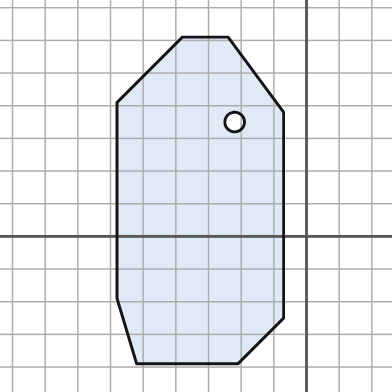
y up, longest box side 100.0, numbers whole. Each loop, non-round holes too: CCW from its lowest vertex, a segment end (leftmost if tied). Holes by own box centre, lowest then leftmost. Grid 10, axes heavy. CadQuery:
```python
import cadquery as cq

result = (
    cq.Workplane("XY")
    .moveTo(-52.0, -39.0)
    .lineTo(-21.0, -39.0)
    .lineTo(-7.0, -25.0)
    .lineTo(-7.0, 38.0)
    .lineTo(-24.0, 61.0)
    .lineTo(-38.0, 61.0)
    .lineTo(-58.0, 41.0)
    .lineTo(-58.0, -19.0)
    .close()
    .moveTo(-22.0, 35.0)
    .circle(3.0)
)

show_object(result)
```